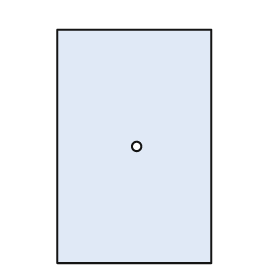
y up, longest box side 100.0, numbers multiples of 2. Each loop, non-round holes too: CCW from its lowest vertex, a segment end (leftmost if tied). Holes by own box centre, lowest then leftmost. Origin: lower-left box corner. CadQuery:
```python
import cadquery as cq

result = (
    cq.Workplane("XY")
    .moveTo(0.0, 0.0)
    .lineTo(66.0, 0.0)
    .lineTo(66.0, 100.0)
    .lineTo(0.0, 100.0)
    .close()
    .moveTo(34.0, 50.0)
    .circle(2.0)
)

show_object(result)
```